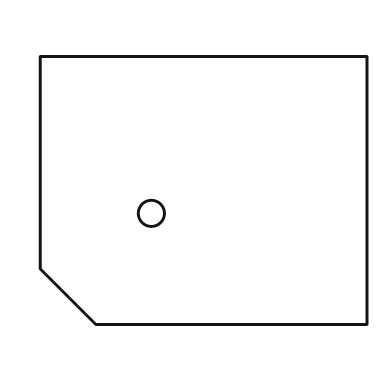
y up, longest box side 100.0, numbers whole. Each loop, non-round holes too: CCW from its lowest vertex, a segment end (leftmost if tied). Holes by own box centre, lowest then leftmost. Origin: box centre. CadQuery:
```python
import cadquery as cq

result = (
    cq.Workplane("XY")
    .moveTo(-33.0, -41.0)
    .lineTo(50.0, -41.0)
    .lineTo(50.0, 41.0)
    .lineTo(-50.0, 41.0)
    .lineTo(-50.0, -24.0)
    .close()
    .moveTo(-16.0, -7.0)
    .circle(4.0)
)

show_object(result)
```